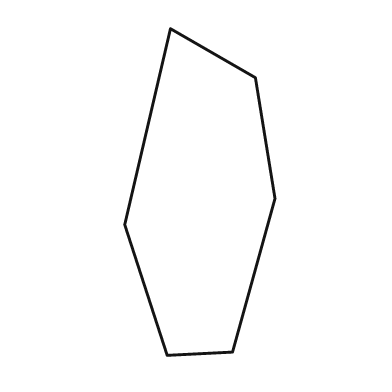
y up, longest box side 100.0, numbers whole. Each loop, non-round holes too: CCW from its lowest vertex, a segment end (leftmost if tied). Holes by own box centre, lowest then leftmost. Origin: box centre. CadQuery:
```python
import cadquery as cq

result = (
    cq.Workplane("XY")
    .moveTo(-10.0, -50.0)
    .lineTo(10.0, -49.0)
    .lineTo(23.0, -2.0)
    .lineTo(17.0, 35.0)
    .lineTo(-9.0, 50.0)
    .lineTo(-23.0, -10.0)
    .close()
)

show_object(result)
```